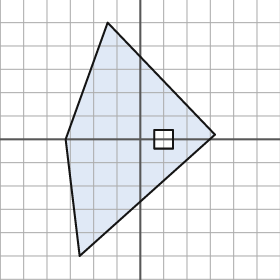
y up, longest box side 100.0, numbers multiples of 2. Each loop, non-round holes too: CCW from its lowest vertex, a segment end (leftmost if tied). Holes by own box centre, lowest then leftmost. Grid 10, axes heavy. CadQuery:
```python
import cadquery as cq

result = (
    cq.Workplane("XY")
    .moveTo(-26.0, -50.0)
    .lineTo(32.0, 2.0)
    .lineTo(-14.0, 50.0)
    .lineTo(-32.0, 0.0)
    .close()
    .moveTo(6.0, -4.0)
    .lineTo(14.0, -4.0)
    .lineTo(14.0, 4.0)
    .lineTo(6.0, 4.0)
    .close()
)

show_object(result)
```